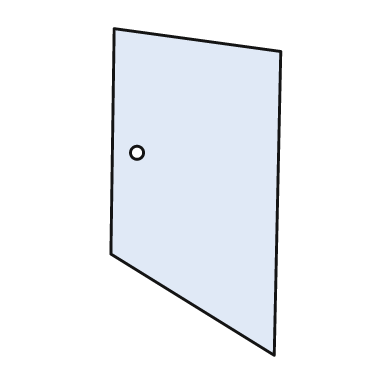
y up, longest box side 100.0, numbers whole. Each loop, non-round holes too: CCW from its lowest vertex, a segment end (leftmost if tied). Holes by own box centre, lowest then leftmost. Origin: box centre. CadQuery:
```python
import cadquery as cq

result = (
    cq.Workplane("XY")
    .moveTo(24.0, -50.0)
    .lineTo(26.0, 43.0)
    .lineTo(-25.0, 50.0)
    .lineTo(-26.0, -19.0)
    .close()
    .moveTo(-18.0, 12.0)
    .circle(2.0)
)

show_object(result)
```